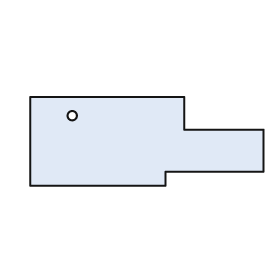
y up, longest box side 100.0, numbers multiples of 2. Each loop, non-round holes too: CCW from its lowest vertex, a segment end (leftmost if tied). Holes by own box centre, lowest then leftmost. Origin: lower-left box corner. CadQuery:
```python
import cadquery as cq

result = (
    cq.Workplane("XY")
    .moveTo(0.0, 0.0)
    .lineTo(58.0, 0.0)
    .lineTo(58.0, 6.0)
    .lineTo(100.0, 6.0)
    .lineTo(100.0, 24.0)
    .lineTo(66.0, 24.0)
    .lineTo(66.0, 38.0)
    .lineTo(0.0, 38.0)
    .close()
    .moveTo(18.0, 30.0)
    .circle(2.0)
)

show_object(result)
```